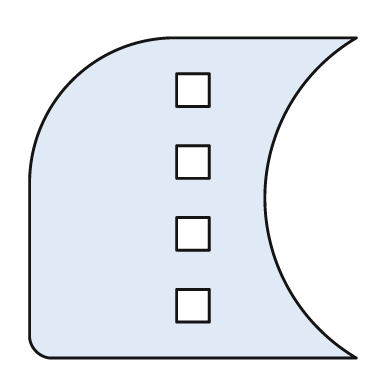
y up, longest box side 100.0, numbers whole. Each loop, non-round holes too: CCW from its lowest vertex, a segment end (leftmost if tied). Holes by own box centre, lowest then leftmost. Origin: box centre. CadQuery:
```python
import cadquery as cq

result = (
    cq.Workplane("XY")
    .moveTo(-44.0, -49.0)
    .lineTo(50.0, -49.0)
    .threePointArc((22.0, 0.0), (50.0, 49.0))
    .lineTo(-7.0, 49.0)
    .threePointArc((-37.0, 36.0), (-50.0, 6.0))
    .lineTo(-50.0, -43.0)
    .threePointArc((-48.0, -47.0), (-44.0, -49.0))
    .close()
    .moveTo(-5.0, -38.0)
    .lineTo(5.0, -38.0)
    .lineTo(5.0, -28.0)
    .lineTo(-5.0, -28.0)
    .close()
    .moveTo(-5.0, -16.0)
    .lineTo(5.0, -16.0)
    .lineTo(5.0, -6.0)
    .lineTo(-5.0, -6.0)
    .close()
    .moveTo(-5.0, 6.0)
    .lineTo(5.0, 6.0)
    .lineTo(5.0, 16.0)
    .lineTo(-5.0, 16.0)
    .close()
    .moveTo(-5.0, 28.0)
    .lineTo(5.0, 28.0)
    .lineTo(5.0, 38.0)
    .lineTo(-5.0, 38.0)
    .close()
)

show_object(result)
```